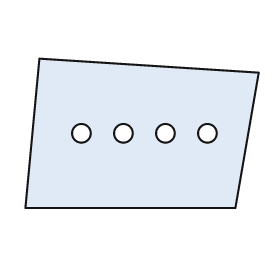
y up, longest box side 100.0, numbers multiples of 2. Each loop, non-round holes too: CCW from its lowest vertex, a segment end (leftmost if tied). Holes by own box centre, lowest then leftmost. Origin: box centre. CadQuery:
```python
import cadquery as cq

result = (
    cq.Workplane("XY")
    .moveTo(-50.0, -32.0)
    .lineTo(40.0, -32.0)
    .lineTo(50.0, 26.0)
    .lineTo(-44.0, 32.0)
    .close()
    .moveTo(-26.0, 0.0)
    .circle(4.0)
    .moveTo(-8.0, 0.0)
    .circle(4.0)
    .moveTo(10.0, 0.0)
    .circle(4.0)
    .moveTo(28.0, 0.0)
    .circle(4.0)
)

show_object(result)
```